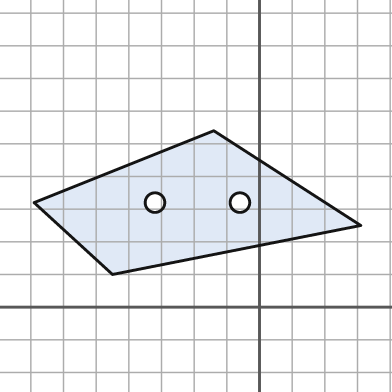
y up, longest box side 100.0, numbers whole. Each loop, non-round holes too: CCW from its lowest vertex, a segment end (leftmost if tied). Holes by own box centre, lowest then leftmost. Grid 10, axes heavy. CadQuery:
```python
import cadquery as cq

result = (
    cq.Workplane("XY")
    .moveTo(-45.0, 10.0)
    .lineTo(31.0, 25.0)
    .lineTo(-14.0, 54.0)
    .lineTo(-69.0, 32.0)
    .close()
    .moveTo(-32.0, 32.0)
    .circle(3.0)
    .moveTo(-6.0, 32.0)
    .circle(3.0)
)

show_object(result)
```